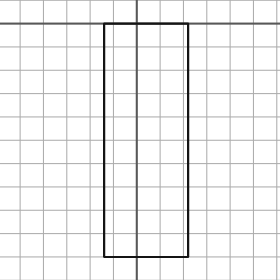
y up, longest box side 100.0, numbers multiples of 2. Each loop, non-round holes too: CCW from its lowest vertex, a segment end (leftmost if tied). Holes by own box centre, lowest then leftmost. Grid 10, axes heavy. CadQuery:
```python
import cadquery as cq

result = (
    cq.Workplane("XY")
    .moveTo(-14.0, -100.0)
    .lineTo(22.0, -100.0)
    .lineTo(22.0, 0.0)
    .lineTo(-14.0, 0.0)
    .close()
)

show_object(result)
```